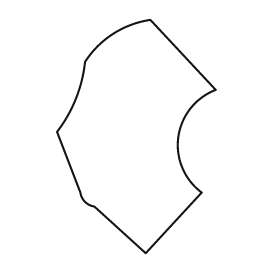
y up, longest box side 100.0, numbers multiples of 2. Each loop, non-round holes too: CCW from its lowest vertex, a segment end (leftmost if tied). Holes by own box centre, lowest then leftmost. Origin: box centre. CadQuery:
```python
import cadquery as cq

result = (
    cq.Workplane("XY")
    .moveTo(4.0, -50.0)
    .lineTo(28.0, -24.0)
    .threePointArc((18.0, 0.0), (34.0, 20.0))
    .lineTo(6.0, 50.0)
    .threePointArc((-10.0, 44.0), (-22.0, 32.0))
    .threePointArc((-26.0, 16.0), (-34.0, 2.0))
    .lineTo(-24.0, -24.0)
    .threePointArc((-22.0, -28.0), (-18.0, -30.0))
    .close()
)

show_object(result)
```